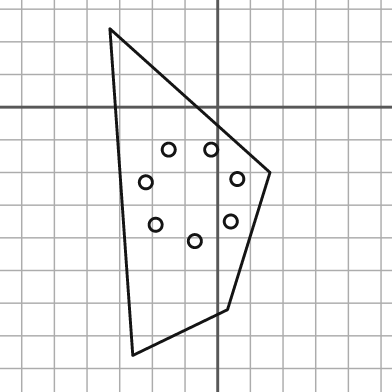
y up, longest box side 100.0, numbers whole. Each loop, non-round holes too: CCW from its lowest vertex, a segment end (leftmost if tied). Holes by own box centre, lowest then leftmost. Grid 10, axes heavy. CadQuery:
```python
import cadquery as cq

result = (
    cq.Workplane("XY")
    .moveTo(-26.0, -76.0)
    .lineTo(3.0, -62.0)
    .lineTo(16.0, -20.0)
    .lineTo(-33.0, 24.0)
    .close()
    .moveTo(-7.0, -41.0)
    .circle(2.0)
    .moveTo(-19.0, -36.0)
    .circle(2.0)
    .moveTo(4.0, -35.0)
    .circle(2.0)
    .moveTo(-22.0, -23.0)
    .circle(2.0)
    .moveTo(6.0, -22.0)
    .circle(2.0)
    .moveTo(-15.0, -13.0)
    .circle(2.0)
    .moveTo(-2.0, -13.0)
    .circle(2.0)
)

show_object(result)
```